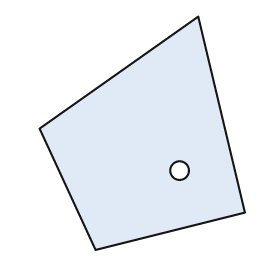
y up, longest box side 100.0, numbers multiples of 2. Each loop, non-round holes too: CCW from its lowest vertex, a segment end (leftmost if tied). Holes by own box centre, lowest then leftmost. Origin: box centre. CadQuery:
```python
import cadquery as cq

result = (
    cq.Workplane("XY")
    .moveTo(-20.0, -50.0)
    .lineTo(44.0, -34.0)
    .lineTo(24.0, 50.0)
    .lineTo(-44.0, 2.0)
    .close()
    .moveTo(16.0, -16.0)
    .circle(4.0)
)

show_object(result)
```